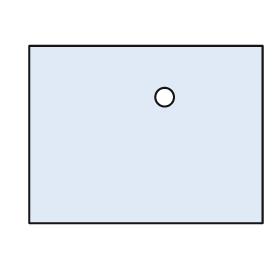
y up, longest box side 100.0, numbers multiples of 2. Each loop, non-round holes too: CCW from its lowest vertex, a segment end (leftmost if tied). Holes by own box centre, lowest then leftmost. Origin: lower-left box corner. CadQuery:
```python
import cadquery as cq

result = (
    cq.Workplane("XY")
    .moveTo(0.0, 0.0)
    .lineTo(100.0, 0.0)
    .lineTo(100.0, 76.0)
    .lineTo(0.0, 76.0)
    .close()
    .moveTo(58.0, 54.0)
    .circle(4.0)
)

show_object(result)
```